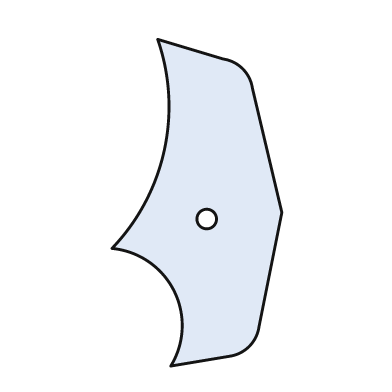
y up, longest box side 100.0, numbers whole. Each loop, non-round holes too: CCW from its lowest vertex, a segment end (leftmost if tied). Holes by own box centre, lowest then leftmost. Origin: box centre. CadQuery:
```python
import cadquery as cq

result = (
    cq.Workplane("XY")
    .moveTo(-8.0, -50.0)
    .lineTo(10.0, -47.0)
    .threePointArc((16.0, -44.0), (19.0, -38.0))
    .lineTo(26.0, -3.0)
    .lineTo(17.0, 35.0)
    .threePointArc((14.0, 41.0), (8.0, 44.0))
    .lineTo(-12.0, 50.0)
    .threePointArc((-10.0, 16.0), (-26.0, -14.0))
    .threePointArc((-7.0, -27.0), (-8.0, -50.0))
    .close()
    .moveTo(3.0, -5.0)
    .circle(3.0)
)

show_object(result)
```